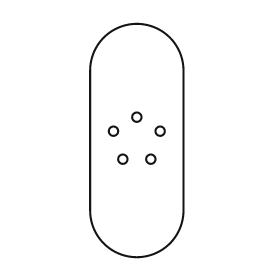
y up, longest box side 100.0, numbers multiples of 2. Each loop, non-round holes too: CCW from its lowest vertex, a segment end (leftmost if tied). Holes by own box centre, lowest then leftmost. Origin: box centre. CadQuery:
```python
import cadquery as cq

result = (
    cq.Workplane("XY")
    .moveTo(-20.0, -30.0)
    .threePointArc((0.0, -50.0), (20.0, -30.0))
    .lineTo(20.0, 30.0)
    .threePointArc((0.0, 50.0), (-20.0, 30.0))
    .close()
    .moveTo(-6.0, -8.0)
    .circle(2.0)
    .moveTo(6.0, -8.0)
    .circle(2.0)
    .moveTo(-10.0, 4.0)
    .circle(2.0)
    .moveTo(10.0, 4.0)
    .circle(2.0)
    .moveTo(0.0, 10.0)
    .circle(2.0)
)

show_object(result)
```